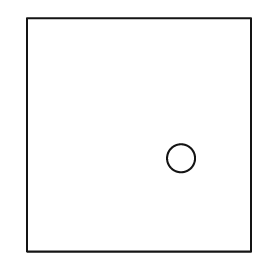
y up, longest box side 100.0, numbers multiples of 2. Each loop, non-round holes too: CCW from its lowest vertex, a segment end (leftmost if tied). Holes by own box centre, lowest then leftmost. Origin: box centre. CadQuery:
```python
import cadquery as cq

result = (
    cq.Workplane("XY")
    .moveTo(-48.0, -50.0)
    .lineTo(48.0, -50.0)
    .lineTo(48.0, 50.0)
    .lineTo(-48.0, 50.0)
    .close()
    .moveTo(18.0, -10.0)
    .circle(6.0)
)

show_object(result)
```